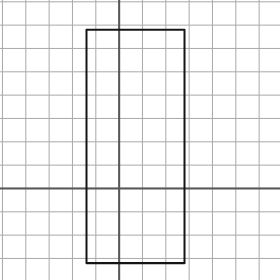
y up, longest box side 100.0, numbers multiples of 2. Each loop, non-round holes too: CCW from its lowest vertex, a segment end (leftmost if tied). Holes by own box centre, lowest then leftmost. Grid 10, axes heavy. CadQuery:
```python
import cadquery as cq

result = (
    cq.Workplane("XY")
    .moveTo(-14.0, -32.0)
    .lineTo(28.0, -32.0)
    .lineTo(28.0, 68.0)
    .lineTo(-14.0, 68.0)
    .close()
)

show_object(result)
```